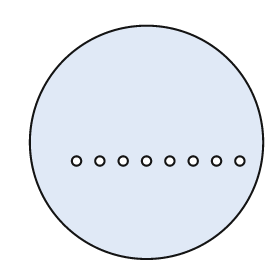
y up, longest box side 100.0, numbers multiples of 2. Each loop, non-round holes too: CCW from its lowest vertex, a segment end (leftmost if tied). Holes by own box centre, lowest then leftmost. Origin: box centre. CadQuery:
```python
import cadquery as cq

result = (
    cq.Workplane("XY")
    .moveTo(0.0, 0.0)
    .circle(50.0)
    .moveTo(-30.0, -8.0)
    .circle(2.0)
    .moveTo(-20.0, -8.0)
    .circle(2.0)
    .moveTo(-10.0, -8.0)
    .circle(2.0)
    .moveTo(0.0, -8.0)
    .circle(2.0)
    .moveTo(10.0, -8.0)
    .circle(2.0)
    .moveTo(20.0, -8.0)
    .circle(2.0)
    .moveTo(30.0, -8.0)
    .circle(2.0)
    .moveTo(40.0, -8.0)
    .circle(2.0)
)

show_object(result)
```